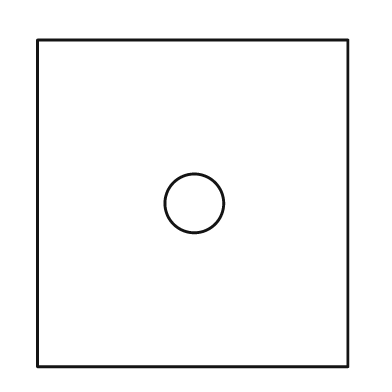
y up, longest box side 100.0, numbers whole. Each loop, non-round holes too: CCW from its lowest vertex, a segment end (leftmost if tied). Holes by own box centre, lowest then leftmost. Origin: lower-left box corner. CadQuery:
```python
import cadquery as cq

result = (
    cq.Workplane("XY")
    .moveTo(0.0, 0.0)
    .lineTo(95.0, 0.0)
    .lineTo(95.0, 100.0)
    .lineTo(0.0, 100.0)
    .close()
    .moveTo(48.0, 50.0)
    .circle(9.0)
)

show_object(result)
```